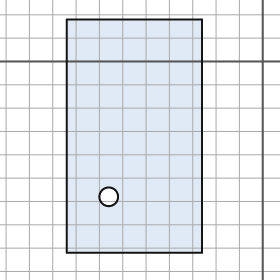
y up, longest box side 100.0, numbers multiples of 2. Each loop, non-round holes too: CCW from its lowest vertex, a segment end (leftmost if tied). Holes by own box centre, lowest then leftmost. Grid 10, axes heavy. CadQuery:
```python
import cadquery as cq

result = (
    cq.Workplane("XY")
    .moveTo(-84.0, -82.0)
    .lineTo(-26.0, -82.0)
    .lineTo(-26.0, 18.0)
    .lineTo(-84.0, 18.0)
    .close()
    .moveTo(-66.0, -58.0)
    .circle(4.0)
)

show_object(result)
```